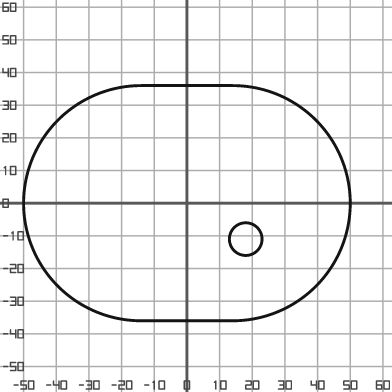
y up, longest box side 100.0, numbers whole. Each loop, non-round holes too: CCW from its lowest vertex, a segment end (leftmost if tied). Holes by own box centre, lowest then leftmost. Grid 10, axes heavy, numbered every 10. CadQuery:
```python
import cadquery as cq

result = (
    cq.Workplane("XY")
    .moveTo(-14.0, -36.0)
    .lineTo(14.0, -36.0)
    .threePointArc((50.0, 0.0), (14.0, 36.0))
    .lineTo(-14.0, 36.0)
    .threePointArc((-50.0, 0.0), (-14.0, -36.0))
    .close()
    .moveTo(18.0, -11.0)
    .circle(5.0)
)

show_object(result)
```